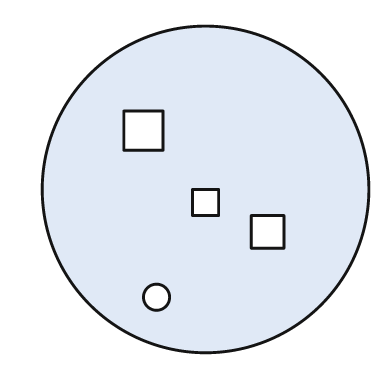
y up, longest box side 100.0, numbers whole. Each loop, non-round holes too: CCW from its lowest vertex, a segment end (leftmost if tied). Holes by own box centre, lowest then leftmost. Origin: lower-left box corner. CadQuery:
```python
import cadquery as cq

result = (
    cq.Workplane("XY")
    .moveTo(50.0, 50.0)
    .circle(50.0)
    .moveTo(35.0, 17.0)
    .circle(4.0)
    .moveTo(64.0, 32.0)
    .lineTo(74.0, 32.0)
    .lineTo(74.0, 42.0)
    .lineTo(64.0, 42.0)
    .close()
    .moveTo(46.0, 42.0)
    .lineTo(54.0, 42.0)
    .lineTo(54.0, 50.0)
    .lineTo(46.0, 50.0)
    .close()
    .moveTo(25.0, 62.0)
    .lineTo(37.0, 62.0)
    .lineTo(37.0, 74.0)
    .lineTo(25.0, 74.0)
    .close()
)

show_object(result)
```